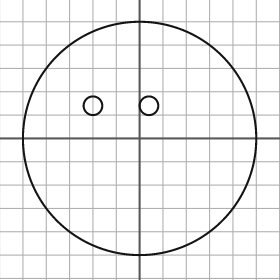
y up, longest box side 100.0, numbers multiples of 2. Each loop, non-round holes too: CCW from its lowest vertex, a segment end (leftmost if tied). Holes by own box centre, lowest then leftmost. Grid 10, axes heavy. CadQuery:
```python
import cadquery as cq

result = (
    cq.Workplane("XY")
    .moveTo(0.0, 0.0)
    .circle(50.0)
    .moveTo(-20.0, 14.0)
    .circle(4.0)
    .moveTo(4.0, 14.0)
    .circle(4.0)
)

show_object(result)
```